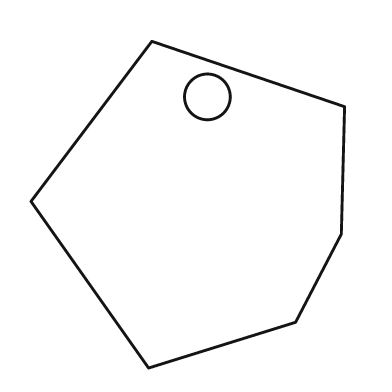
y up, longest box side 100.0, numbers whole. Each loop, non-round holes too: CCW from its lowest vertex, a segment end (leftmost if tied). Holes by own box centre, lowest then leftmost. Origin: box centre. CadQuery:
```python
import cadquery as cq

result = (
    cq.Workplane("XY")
    .moveTo(-12.0, -50.0)
    .lineTo(33.0, -36.0)
    .lineTo(47.0, -9.0)
    .lineTo(48.0, 30.0)
    .lineTo(-11.0, 50.0)
    .lineTo(-48.0, 1.0)
    .close()
    .moveTo(6.0, 33.0)
    .circle(7.0)
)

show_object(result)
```